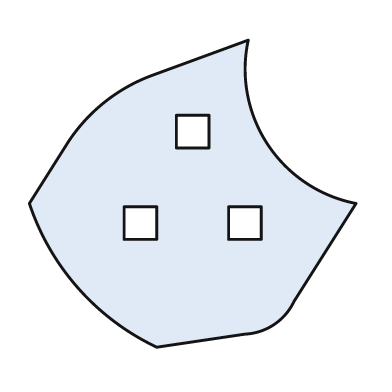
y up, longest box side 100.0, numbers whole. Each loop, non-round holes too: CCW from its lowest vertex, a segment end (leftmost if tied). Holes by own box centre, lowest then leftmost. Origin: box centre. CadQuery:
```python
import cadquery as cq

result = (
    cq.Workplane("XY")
    .moveTo(-11.0, -47.0)
    .lineTo(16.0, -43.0)
    .threePointArc((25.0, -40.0), (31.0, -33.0))
    .lineTo(50.0, -3.0)
    .threePointArc((23.0, 15.0), (17.0, 47.0))
    .lineTo(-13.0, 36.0)
    .threePointArc((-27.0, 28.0), (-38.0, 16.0))
    .lineTo(-50.0, -3.0)
    .threePointArc((-35.0, -29.0), (-11.0, -47.0))
    .close()
    .moveTo(-21.0, -14.0)
    .lineTo(-11.0, -14.0)
    .lineTo(-11.0, -4.0)
    .lineTo(-21.0, -4.0)
    .close()
    .moveTo(11.0, -14.0)
    .lineTo(21.0, -14.0)
    .lineTo(21.0, -4.0)
    .lineTo(11.0, -4.0)
    .close()
    .moveTo(-5.0, 14.0)
    .lineTo(5.0, 14.0)
    .lineTo(5.0, 24.0)
    .lineTo(-5.0, 24.0)
    .close()
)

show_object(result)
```